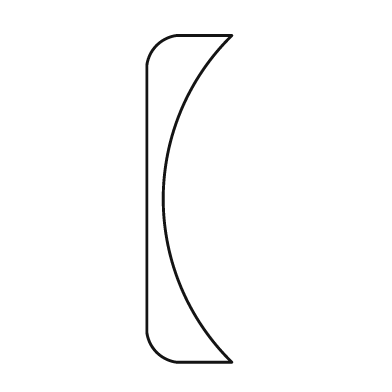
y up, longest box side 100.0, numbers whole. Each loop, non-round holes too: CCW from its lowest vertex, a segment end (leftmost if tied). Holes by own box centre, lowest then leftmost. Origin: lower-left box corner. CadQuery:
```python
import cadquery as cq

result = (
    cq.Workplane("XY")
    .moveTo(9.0, 0.0)
    .lineTo(26.0, 0.0)
    .threePointArc((5.0, 50.0), (26.0, 100.0))
    .lineTo(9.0, 100.0)
    .threePointArc((3.0, 97.0), (0.0, 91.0))
    .lineTo(0.0, 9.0)
    .threePointArc((3.0, 3.0), (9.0, 0.0))
    .close()
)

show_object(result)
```